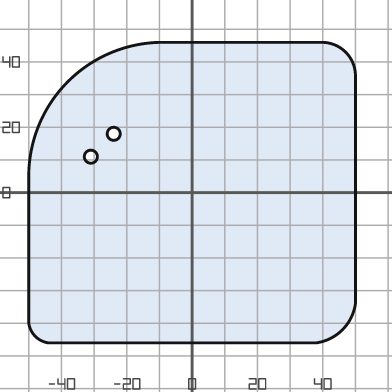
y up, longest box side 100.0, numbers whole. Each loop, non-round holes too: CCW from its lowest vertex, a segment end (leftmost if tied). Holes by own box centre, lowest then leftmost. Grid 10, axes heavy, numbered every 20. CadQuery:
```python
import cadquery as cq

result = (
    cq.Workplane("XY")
    .moveTo(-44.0, -46.0)
    .lineTo(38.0, -46.0)
    .threePointArc((46.0, -42.0), (50.0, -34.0))
    .lineTo(50.0, 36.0)
    .threePointArc((47.0, 43.0), (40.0, 46.0))
    .lineTo(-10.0, 46.0)
    .threePointArc((-38.0, 34.0), (-50.0, 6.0))
    .lineTo(-50.0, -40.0)
    .threePointArc((-48.0, -44.0), (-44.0, -46.0))
    .close()
    .moveTo(-31.0, 11.0)
    .circle(2.0)
    .moveTo(-24.0, 18.0)
    .circle(2.0)
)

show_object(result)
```